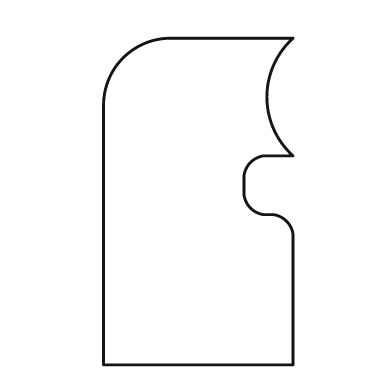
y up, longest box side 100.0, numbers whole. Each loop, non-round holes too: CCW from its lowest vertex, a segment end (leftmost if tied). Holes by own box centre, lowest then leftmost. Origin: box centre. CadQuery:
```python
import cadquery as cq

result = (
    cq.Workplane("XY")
    .moveTo(-29.0, -50.0)
    .lineTo(29.0, -50.0)
    .lineTo(29.0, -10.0)
    .threePointArc((27.0, -6.0), (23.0, -4.0))
    .lineTo(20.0, -4.0)
    .threePointArc((16.0, -2.0), (14.0, 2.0))
    .lineTo(14.0, 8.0)
    .threePointArc((16.0, 12.0), (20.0, 14.0))
    .lineTo(29.0, 14.0)
    .threePointArc((21.0, 32.0), (29.0, 50.0))
    .lineTo(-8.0, 50.0)
    .threePointArc((-23.0, 44.0), (-29.0, 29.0))
    .close()
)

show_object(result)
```